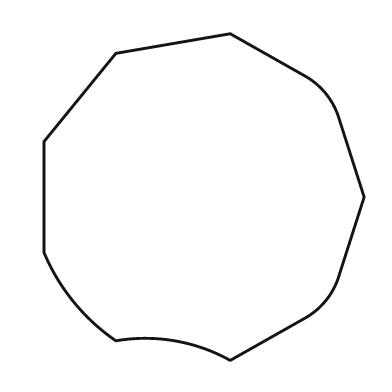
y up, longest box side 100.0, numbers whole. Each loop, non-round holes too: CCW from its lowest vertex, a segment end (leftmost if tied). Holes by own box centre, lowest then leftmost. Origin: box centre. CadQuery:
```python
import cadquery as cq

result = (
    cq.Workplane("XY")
    .moveTo(8.0, -50.0)
    .lineTo(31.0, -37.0)
    .threePointArc((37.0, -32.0), (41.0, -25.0))
    .lineTo(49.0, 0.0)
    .lineTo(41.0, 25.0)
    .threePointArc((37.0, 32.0), (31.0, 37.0))
    .lineTo(8.0, 50.0)
    .lineTo(-27.0, 44.0)
    .lineTo(-49.0, 17.0)
    .lineTo(-49.0, -17.0)
    .threePointArc((-40.0, -32.0), (-27.0, -44.0))
    .threePointArc((-9.0, -44.0), (8.0, -50.0))
    .close()
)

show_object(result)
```